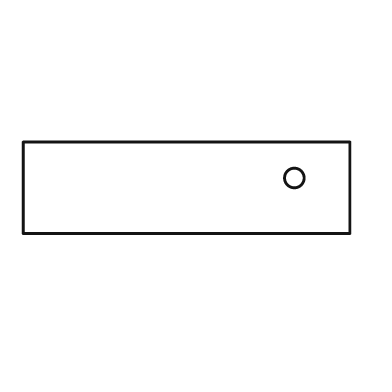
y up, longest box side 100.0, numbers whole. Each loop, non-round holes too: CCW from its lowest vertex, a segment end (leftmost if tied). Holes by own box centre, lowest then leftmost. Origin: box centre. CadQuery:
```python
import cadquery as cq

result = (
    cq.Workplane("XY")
    .moveTo(-50.0, -14.0)
    .lineTo(50.0, -14.0)
    .lineTo(50.0, 14.0)
    .lineTo(-50.0, 14.0)
    .close()
    .moveTo(33.0, 3.0)
    .circle(3.0)
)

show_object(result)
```